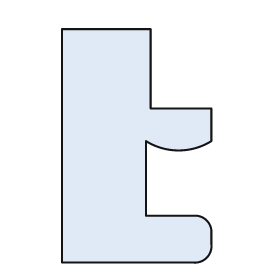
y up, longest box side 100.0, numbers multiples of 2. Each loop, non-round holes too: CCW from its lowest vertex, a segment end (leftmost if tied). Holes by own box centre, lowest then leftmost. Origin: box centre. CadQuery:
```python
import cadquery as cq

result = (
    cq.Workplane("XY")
    .moveTo(-32.0, -50.0)
    .lineTo(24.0, -50.0)
    .threePointArc((30.0, -48.0), (32.0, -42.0))
    .lineTo(32.0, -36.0)
    .threePointArc((30.0, -32.0), (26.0, -30.0))
    .lineTo(4.0, -30.0)
    .lineTo(4.0, 2.0)
    .threePointArc((18.0, -2.0), (32.0, 2.0))
    .lineTo(32.0, 16.0)
    .lineTo(6.0, 16.0)
    .lineTo(6.0, 50.0)
    .lineTo(-32.0, 50.0)
    .close()
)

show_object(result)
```